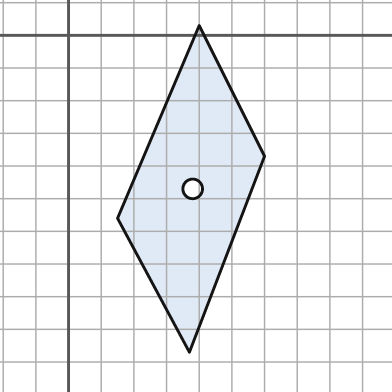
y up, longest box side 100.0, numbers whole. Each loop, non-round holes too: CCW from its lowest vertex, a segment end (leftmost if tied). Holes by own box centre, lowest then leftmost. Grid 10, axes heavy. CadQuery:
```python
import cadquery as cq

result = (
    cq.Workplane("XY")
    .moveTo(37.0, -97.0)
    .lineTo(60.0, -37.0)
    .lineTo(40.0, 3.0)
    .lineTo(15.0, -56.0)
    .close()
    .moveTo(38.0, -47.0)
    .circle(3.0)
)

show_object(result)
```